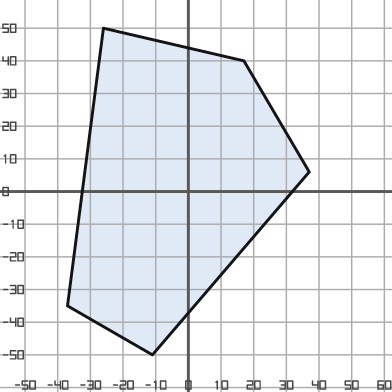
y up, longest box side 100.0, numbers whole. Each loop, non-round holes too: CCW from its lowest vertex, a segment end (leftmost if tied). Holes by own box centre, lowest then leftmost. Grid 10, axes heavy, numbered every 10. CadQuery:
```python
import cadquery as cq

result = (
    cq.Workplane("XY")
    .moveTo(-11.0, -50.0)
    .lineTo(37.0, 6.0)
    .lineTo(17.0, 40.0)
    .lineTo(-26.0, 50.0)
    .lineTo(-37.0, -35.0)
    .close()
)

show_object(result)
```